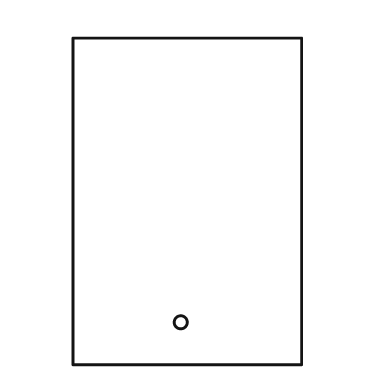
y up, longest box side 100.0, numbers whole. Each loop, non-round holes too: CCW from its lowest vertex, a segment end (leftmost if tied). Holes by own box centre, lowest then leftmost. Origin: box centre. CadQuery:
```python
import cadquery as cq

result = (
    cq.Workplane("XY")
    .moveTo(-35.0, -50.0)
    .lineTo(35.0, -50.0)
    .lineTo(35.0, 50.0)
    .lineTo(-35.0, 50.0)
    .close()
    .moveTo(-2.0, -37.0)
    .circle(2.0)
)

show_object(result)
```